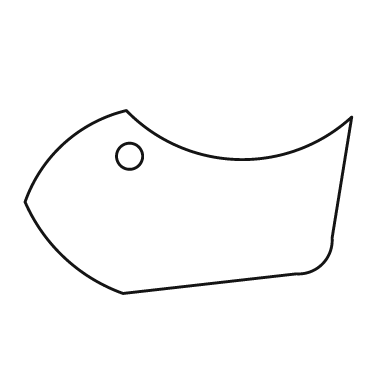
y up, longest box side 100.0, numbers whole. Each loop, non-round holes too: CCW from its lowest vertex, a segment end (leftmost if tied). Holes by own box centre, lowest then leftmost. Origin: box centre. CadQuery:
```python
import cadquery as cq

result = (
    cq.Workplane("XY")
    .moveTo(-20.0, -28.0)
    .lineTo(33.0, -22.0)
    .threePointArc((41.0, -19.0), (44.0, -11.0))
    .lineTo(50.0, 26.0)
    .threePointArc((15.0, 13.0), (-19.0, 28.0))
    .threePointArc((-38.0, 18.0), (-50.0, 0.0))
    .threePointArc((-38.0, -17.0), (-20.0, -28.0))
    .close()
    .moveTo(-18.0, 14.0)
    .circle(4.0)
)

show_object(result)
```